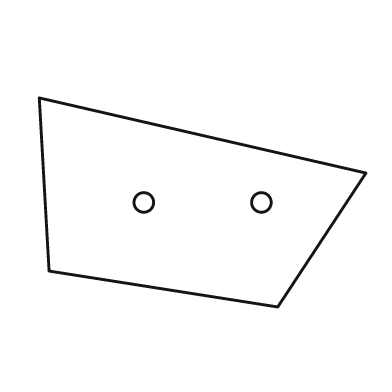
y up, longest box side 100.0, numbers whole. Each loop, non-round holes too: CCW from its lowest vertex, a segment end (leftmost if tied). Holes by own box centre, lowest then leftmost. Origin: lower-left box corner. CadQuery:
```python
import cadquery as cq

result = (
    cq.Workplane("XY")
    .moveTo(73.0, 0.0)
    .lineTo(100.0, 41.0)
    .lineTo(0.0, 64.0)
    .lineTo(3.0, 11.0)
    .close()
    .moveTo(32.0, 32.0)
    .circle(3.0)
    .moveTo(68.0, 32.0)
    .circle(3.0)
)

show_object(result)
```